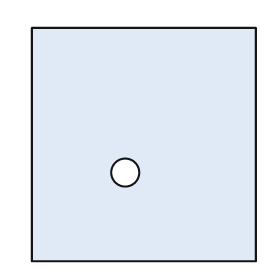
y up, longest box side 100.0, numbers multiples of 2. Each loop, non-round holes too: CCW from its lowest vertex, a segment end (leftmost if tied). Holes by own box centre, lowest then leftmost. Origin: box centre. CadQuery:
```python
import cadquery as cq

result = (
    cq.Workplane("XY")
    .moveTo(-48.0, -50.0)
    .lineTo(48.0, -50.0)
    .lineTo(48.0, 50.0)
    .lineTo(-48.0, 50.0)
    .close()
    .moveTo(-8.0, -12.0)
    .circle(6.0)
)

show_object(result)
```